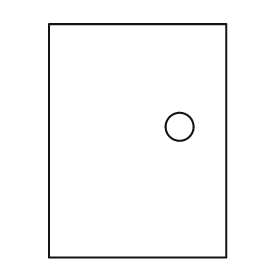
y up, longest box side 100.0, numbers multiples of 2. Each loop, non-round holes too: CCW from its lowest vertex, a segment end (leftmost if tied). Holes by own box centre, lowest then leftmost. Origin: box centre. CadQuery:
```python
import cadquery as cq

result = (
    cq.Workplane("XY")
    .moveTo(-38.0, -50.0)
    .lineTo(38.0, -50.0)
    .lineTo(38.0, 50.0)
    .lineTo(-38.0, 50.0)
    .close()
    .moveTo(18.0, 6.0)
    .circle(6.0)
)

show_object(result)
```